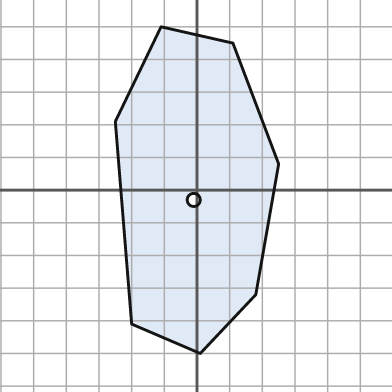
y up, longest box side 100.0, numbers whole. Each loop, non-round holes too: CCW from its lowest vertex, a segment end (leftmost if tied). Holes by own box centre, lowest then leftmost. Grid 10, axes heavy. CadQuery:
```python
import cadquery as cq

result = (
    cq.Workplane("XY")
    .moveTo(1.0, -50.0)
    .lineTo(18.0, -32.0)
    .lineTo(25.0, 8.0)
    .lineTo(11.0, 45.0)
    .lineTo(-11.0, 50.0)
    .lineTo(-25.0, 21.0)
    .lineTo(-20.0, -41.0)
    .close()
    .moveTo(-1.0, -3.0)
    .circle(2.0)
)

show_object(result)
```